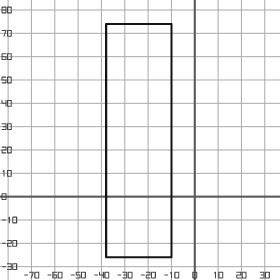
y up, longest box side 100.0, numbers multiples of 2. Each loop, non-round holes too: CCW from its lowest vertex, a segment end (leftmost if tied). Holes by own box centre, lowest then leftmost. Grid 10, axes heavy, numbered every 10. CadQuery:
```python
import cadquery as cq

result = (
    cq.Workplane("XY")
    .moveTo(-38.0, -26.0)
    .lineTo(-10.0, -26.0)
    .lineTo(-10.0, 74.0)
    .lineTo(-38.0, 74.0)
    .close()
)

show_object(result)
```